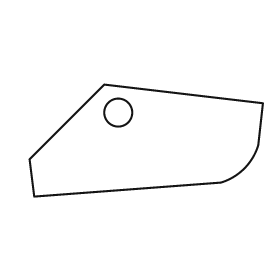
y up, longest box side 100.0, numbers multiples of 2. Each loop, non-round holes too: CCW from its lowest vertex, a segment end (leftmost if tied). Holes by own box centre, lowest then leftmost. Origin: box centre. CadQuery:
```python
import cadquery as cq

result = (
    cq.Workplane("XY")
    .moveTo(-48.0, -24.0)
    .lineTo(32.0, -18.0)
    .threePointArc((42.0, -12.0), (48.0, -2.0))
    .lineTo(50.0, 16.0)
    .lineTo(-18.0, 24.0)
    .lineTo(-50.0, -8.0)
    .close()
    .moveTo(-12.0, 12.0)
    .circle(6.0)
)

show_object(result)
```